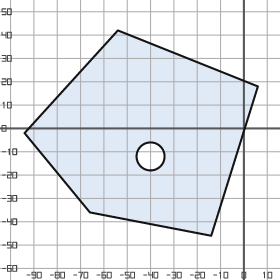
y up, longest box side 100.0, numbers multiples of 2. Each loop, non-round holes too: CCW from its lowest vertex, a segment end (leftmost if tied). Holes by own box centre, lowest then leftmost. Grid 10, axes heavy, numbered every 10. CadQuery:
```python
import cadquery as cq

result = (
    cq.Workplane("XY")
    .moveTo(-14.0, -46.0)
    .lineTo(6.0, 18.0)
    .lineTo(-54.0, 42.0)
    .lineTo(-94.0, -2.0)
    .lineTo(-66.0, -36.0)
    .close()
    .moveTo(-40.0, -12.0)
    .circle(6.0)
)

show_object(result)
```